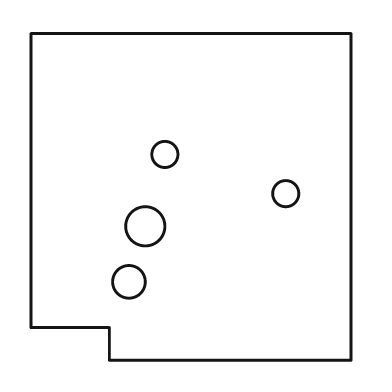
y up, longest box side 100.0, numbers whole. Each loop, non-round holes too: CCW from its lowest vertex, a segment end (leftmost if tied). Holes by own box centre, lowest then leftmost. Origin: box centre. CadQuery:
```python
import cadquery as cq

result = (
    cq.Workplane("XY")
    .moveTo(-25.0, -50.0)
    .lineTo(49.0, -50.0)
    .lineTo(49.0, 50.0)
    .lineTo(-49.0, 50.0)
    .lineTo(-49.0, -40.0)
    .lineTo(-25.0, -40.0)
    .close()
    .moveTo(-19.0, -26.0)
    .circle(5.0)
    .moveTo(-14.0, -9.0)
    .circle(6.0)
    .moveTo(29.0, 1.0)
    .circle(4.0)
    .moveTo(-8.0, 13.0)
    .circle(4.0)
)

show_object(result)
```